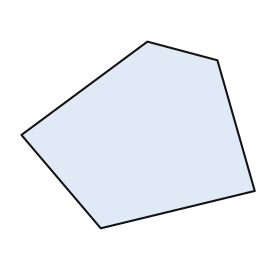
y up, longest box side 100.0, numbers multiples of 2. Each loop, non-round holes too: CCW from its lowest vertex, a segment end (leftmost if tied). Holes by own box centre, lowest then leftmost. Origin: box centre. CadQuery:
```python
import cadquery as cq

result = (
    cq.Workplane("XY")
    .moveTo(-16.0, -40.0)
    .lineTo(50.0, -24.0)
    .lineTo(34.0, 32.0)
    .lineTo(4.0, 40.0)
    .lineTo(-50.0, 0.0)
    .close()
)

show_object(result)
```